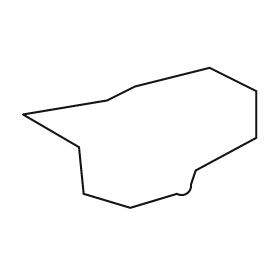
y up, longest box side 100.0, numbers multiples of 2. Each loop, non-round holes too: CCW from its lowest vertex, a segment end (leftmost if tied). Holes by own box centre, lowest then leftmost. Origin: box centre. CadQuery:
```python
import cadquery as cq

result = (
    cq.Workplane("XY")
    .moveTo(-4.0, -30.0)
    .lineTo(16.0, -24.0)
    .threePointArc((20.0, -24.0), (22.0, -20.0))
    .lineTo(24.0, -14.0)
    .lineTo(50.0, 0.0)
    .lineTo(50.0, 20.0)
    .lineTo(30.0, 30.0)
    .lineTo(-2.0, 22.0)
    .lineTo(-14.0, 16.0)
    .lineTo(-50.0, 10.0)
    .lineTo(-26.0, -4.0)
    .lineTo(-24.0, -24.0)
    .close()
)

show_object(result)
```